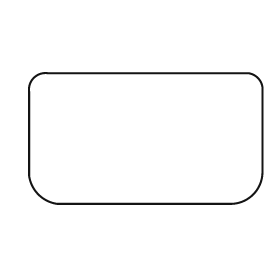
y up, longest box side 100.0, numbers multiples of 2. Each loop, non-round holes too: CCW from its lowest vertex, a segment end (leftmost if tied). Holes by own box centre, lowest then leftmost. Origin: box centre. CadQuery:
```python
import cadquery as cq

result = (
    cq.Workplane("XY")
    .moveTo(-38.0, -28.0)
    .lineTo(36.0, -28.0)
    .threePointArc((46.0, -24.0), (50.0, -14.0))
    .lineTo(50.0, 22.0)
    .threePointArc((48.0, 26.0), (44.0, 28.0))
    .lineTo(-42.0, 28.0)
    .threePointArc((-48.0, 26.0), (-50.0, 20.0))
    .lineTo(-50.0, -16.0)
    .threePointArc((-46.0, -24.0), (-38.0, -28.0))
    .close()
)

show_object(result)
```